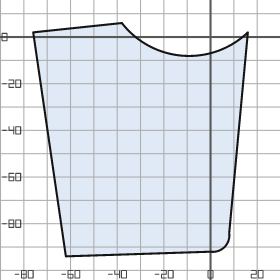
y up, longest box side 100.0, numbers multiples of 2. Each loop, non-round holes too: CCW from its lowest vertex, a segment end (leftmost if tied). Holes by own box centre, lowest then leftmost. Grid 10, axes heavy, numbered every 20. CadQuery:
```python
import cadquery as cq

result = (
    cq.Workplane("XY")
    .moveTo(-62.0, -94.0)
    .lineTo(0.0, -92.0)
    .threePointArc((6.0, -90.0), (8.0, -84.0))
    .lineTo(16.0, 2.0)
    .threePointArc((-12.0, -8.0), (-38.0, 6.0))
    .lineTo(-76.0, 2.0)
    .close()
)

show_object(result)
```